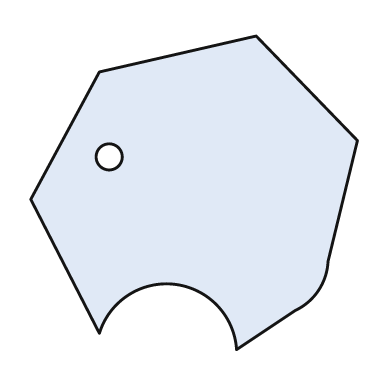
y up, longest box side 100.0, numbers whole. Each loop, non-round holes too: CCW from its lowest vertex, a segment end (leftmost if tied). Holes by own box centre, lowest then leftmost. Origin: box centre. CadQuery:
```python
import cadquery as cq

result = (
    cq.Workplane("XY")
    .moveTo(13.0, -48.0)
    .lineTo(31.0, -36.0)
    .threePointArc((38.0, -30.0), (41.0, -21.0))
    .lineTo(50.0, 16.0)
    .lineTo(19.0, 48.0)
    .lineTo(-29.0, 37.0)
    .lineTo(-50.0, -2.0)
    .lineTo(-29.0, -43.0)
    .threePointArc((-6.0, -28.0), (13.0, -48.0))
    .close()
    .moveTo(-26.0, 11.0)
    .circle(4.0)
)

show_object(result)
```